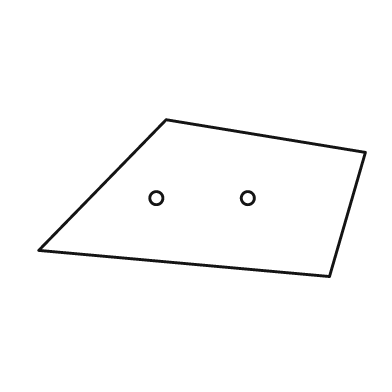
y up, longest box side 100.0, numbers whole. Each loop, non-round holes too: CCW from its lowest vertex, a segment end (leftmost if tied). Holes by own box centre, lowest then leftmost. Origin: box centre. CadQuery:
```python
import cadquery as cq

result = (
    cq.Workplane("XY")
    .moveTo(39.0, -24.0)
    .lineTo(50.0, 14.0)
    .lineTo(-11.0, 24.0)
    .lineTo(-50.0, -16.0)
    .close()
    .moveTo(-14.0, 0.0)
    .circle(2.0)
    .moveTo(14.0, 0.0)
    .circle(2.0)
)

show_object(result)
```